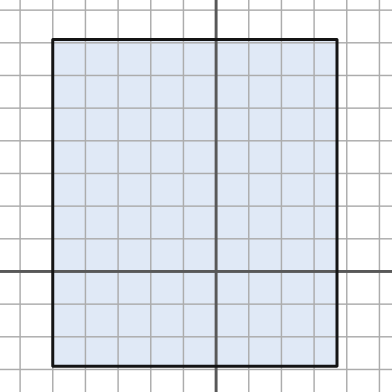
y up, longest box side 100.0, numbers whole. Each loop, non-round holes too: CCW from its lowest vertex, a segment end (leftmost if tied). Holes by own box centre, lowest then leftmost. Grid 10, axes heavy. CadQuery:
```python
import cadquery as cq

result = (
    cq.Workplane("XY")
    .moveTo(-50.0, -29.0)
    .lineTo(37.0, -29.0)
    .lineTo(37.0, 71.0)
    .lineTo(-50.0, 71.0)
    .close()
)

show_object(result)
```